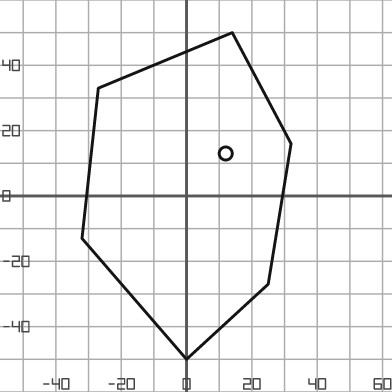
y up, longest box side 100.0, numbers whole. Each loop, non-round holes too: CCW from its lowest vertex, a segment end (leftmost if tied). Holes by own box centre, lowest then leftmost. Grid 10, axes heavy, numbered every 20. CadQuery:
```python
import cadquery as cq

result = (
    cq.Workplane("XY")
    .moveTo(0.0, -50.0)
    .lineTo(25.0, -27.0)
    .lineTo(32.0, 16.0)
    .lineTo(14.0, 50.0)
    .lineTo(-27.0, 33.0)
    .lineTo(-32.0, -13.0)
    .close()
    .moveTo(12.0, 13.0)
    .circle(2.0)
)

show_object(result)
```